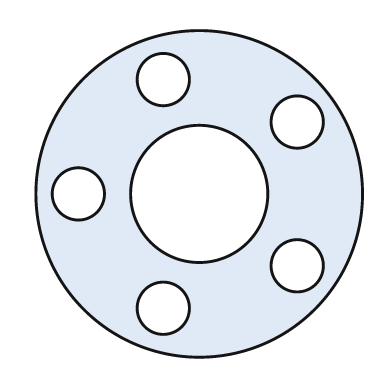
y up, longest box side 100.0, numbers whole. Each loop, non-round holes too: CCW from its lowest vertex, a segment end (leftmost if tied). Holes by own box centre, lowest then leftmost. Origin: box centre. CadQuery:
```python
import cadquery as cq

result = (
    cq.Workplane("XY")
    .moveTo(0.0, 0.0)
    .circle(50.0)
    .moveTo(-11.0, -35.0)
    .circle(8.0)
    .moveTo(30.0, -22.0)
    .circle(8.0)
    .moveTo(-37.0, 0.0)
    .circle(8.0)
    .moveTo(0.0, 0.0)
    .circle(21.0)
    .moveTo(30.0, 22.0)
    .circle(8.0)
    .moveTo(-11.0, 35.0)
    .circle(8.0)
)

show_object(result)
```